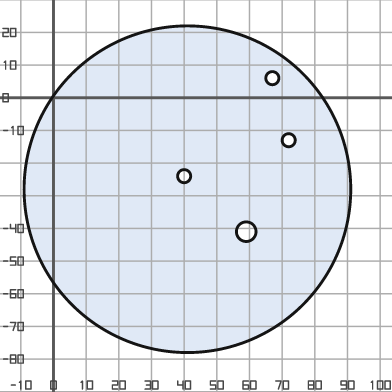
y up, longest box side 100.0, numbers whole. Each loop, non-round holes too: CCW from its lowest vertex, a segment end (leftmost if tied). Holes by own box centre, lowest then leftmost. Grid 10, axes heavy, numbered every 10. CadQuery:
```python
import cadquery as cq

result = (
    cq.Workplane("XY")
    .moveTo(41.0, -28.0)
    .circle(50.0)
    .moveTo(59.0, -41.0)
    .circle(3.0)
    .moveTo(40.0, -24.0)
    .circle(2.0)
    .moveTo(72.0, -13.0)
    .circle(2.0)
    .moveTo(67.0, 6.0)
    .circle(2.0)
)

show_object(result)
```